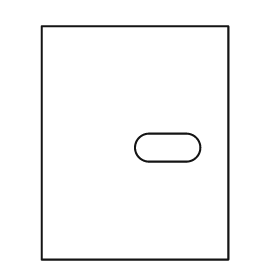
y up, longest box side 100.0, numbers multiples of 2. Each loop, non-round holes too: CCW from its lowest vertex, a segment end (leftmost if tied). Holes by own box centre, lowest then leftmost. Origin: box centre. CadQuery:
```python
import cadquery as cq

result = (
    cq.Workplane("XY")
    .moveTo(-40.0, -50.0)
    .lineTo(40.0, -50.0)
    .lineTo(40.0, 50.0)
    .lineTo(-40.0, 50.0)
    .close()
    .moveTo(6.0, -8.0)
    .lineTo(22.0, -8.0)
    .threePointArc((28.0, -2.0), (22.0, 4.0))
    .lineTo(6.0, 4.0)
    .threePointArc((0.0, -2.0), (6.0, -8.0))
    .close()
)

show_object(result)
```